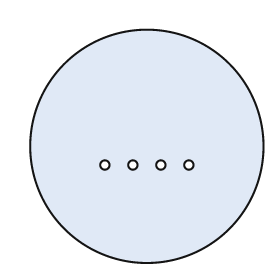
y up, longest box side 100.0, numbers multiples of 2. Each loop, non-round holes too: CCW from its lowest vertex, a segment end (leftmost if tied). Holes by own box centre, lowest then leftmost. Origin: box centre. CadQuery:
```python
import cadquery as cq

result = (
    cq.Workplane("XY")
    .moveTo(0.0, 0.0)
    .circle(50.0)
    .moveTo(-18.0, -8.0)
    .circle(2.0)
    .moveTo(-6.0, -8.0)
    .circle(2.0)
    .moveTo(6.0, -8.0)
    .circle(2.0)
    .moveTo(18.0, -8.0)
    .circle(2.0)
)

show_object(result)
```